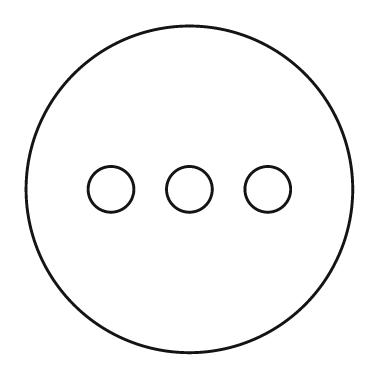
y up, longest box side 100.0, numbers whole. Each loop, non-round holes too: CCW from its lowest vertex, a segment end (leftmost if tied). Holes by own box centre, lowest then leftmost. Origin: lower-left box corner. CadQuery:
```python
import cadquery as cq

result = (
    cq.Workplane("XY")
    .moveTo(50.0, 50.0)
    .circle(50.0)
    .moveTo(26.0, 50.0)
    .circle(7.0)
    .moveTo(50.0, 50.0)
    .circle(7.0)
    .moveTo(74.0, 50.0)
    .circle(7.0)
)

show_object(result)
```